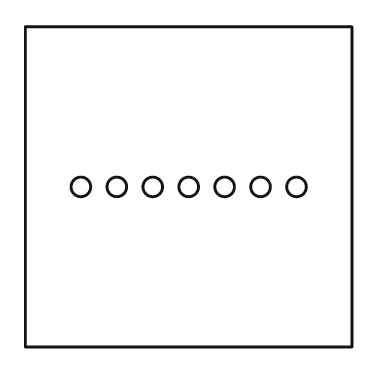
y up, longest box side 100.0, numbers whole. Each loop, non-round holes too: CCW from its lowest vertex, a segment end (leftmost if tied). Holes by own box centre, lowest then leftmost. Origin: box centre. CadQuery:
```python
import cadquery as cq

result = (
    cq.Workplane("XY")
    .moveTo(-50.0, -49.0)
    .lineTo(50.0, -49.0)
    .lineTo(50.0, 49.0)
    .lineTo(-50.0, 49.0)
    .close()
    .moveTo(-33.0, 0.0)
    .circle(3.0)
    .moveTo(-22.0, 0.0)
    .circle(3.0)
    .moveTo(-11.0, 0.0)
    .circle(3.0)
    .moveTo(0.0, 0.0)
    .circle(3.0)
    .moveTo(11.0, 0.0)
    .circle(3.0)
    .moveTo(22.0, 0.0)
    .circle(3.0)
    .moveTo(33.0, 0.0)
    .circle(3.0)
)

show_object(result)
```